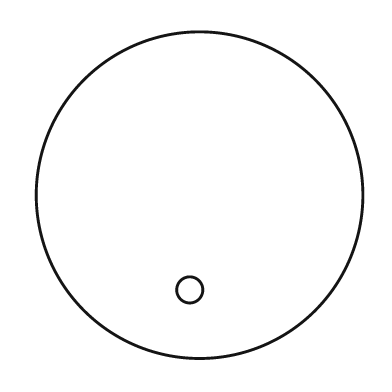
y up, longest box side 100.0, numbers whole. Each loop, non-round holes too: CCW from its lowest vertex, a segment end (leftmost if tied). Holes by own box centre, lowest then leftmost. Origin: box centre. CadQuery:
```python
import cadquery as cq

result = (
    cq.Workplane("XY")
    .moveTo(0.0, 0.0)
    .circle(50.0)
    .moveTo(-3.0, -29.0)
    .circle(4.0)
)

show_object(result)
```